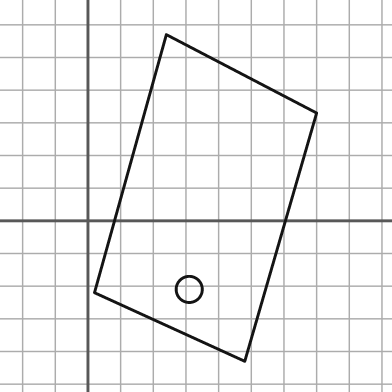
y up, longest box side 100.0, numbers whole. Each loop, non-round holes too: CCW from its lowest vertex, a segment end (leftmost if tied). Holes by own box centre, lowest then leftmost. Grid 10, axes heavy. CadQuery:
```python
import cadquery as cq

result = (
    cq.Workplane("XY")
    .moveTo(48.0, -43.0)
    .lineTo(70.0, 33.0)
    .lineTo(24.0, 57.0)
    .lineTo(2.0, -22.0)
    .close()
    .moveTo(31.0, -21.0)
    .circle(4.0)
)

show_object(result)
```